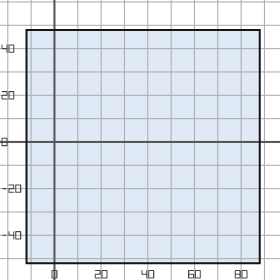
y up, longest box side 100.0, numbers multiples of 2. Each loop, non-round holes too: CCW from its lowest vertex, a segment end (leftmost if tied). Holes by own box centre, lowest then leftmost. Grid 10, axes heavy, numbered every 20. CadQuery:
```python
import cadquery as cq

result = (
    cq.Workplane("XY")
    .moveTo(-12.0, -52.0)
    .lineTo(88.0, -52.0)
    .lineTo(88.0, 48.0)
    .lineTo(-12.0, 48.0)
    .close()
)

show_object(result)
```